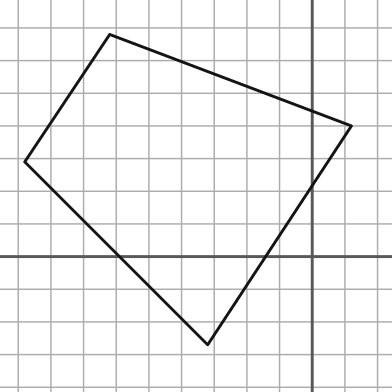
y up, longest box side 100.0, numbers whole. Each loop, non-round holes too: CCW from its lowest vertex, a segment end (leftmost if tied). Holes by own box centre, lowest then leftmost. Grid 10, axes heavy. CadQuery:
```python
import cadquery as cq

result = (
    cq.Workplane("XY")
    .moveTo(-32.0, -27.0)
    .lineTo(12.0, 40.0)
    .lineTo(-62.0, 68.0)
    .lineTo(-88.0, 29.0)
    .close()
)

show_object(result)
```